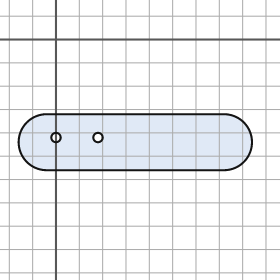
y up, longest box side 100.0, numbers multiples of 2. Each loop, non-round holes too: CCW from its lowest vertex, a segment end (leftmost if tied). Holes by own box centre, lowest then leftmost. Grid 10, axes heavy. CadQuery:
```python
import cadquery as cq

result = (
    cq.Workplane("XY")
    .moveTo(-4.0, -56.0)
    .lineTo(72.0, -56.0)
    .threePointArc((84.0, -44.0), (72.0, -32.0))
    .lineTo(-4.0, -32.0)
    .threePointArc((-16.0, -44.0), (-4.0, -56.0))
    .close()
    .moveTo(0.0, -42.0)
    .circle(2.0)
    .moveTo(18.0, -42.0)
    .circle(2.0)
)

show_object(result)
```